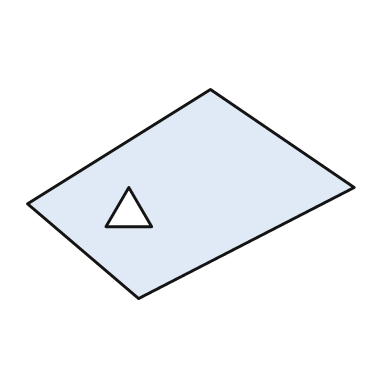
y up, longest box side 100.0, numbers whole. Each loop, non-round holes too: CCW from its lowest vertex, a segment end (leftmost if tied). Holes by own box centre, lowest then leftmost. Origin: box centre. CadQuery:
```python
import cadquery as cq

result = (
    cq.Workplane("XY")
    .moveTo(-16.0, -32.0)
    .lineTo(50.0, 2.0)
    .lineTo(6.0, 32.0)
    .lineTo(-50.0, -3.0)
    .close()
    .moveTo(-26.0, -10.0)
    .lineTo(-12.0, -10.0)
    .lineTo(-19.0, 2.0)
    .close()
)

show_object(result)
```